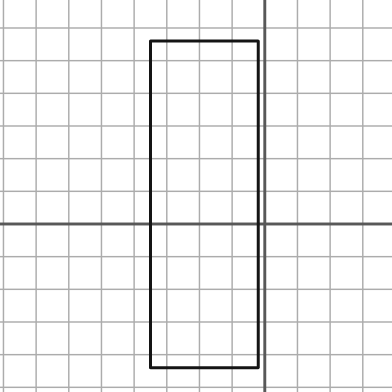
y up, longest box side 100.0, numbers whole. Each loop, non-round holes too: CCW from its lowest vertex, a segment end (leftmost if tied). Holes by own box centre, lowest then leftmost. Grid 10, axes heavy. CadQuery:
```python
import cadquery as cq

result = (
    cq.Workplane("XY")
    .moveTo(-35.0, -44.0)
    .lineTo(-2.0, -44.0)
    .lineTo(-2.0, 56.0)
    .lineTo(-35.0, 56.0)
    .close()
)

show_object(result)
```